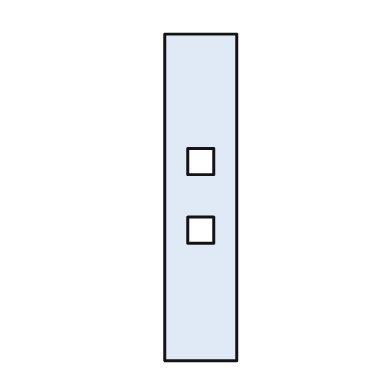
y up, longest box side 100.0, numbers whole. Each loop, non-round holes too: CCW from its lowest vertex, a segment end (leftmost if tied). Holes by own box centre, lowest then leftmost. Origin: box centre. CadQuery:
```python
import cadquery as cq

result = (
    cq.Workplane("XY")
    .moveTo(-11.0, -50.0)
    .lineTo(11.0, -50.0)
    .lineTo(11.0, 50.0)
    .lineTo(-11.0, 50.0)
    .close()
    .moveTo(-4.0, -14.0)
    .lineTo(4.0, -14.0)
    .lineTo(4.0, -6.0)
    .lineTo(-4.0, -6.0)
    .close()
    .moveTo(-4.0, 7.0)
    .lineTo(4.0, 7.0)
    .lineTo(4.0, 15.0)
    .lineTo(-4.0, 15.0)
    .close()
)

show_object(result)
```